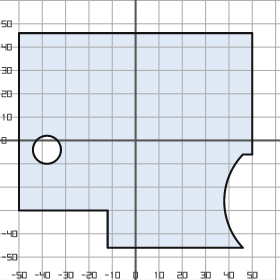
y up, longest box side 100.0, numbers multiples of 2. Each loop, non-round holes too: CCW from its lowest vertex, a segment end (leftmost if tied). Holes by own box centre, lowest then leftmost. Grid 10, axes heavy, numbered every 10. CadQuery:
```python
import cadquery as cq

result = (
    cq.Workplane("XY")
    .moveTo(-12.0, -46.0)
    .lineTo(46.0, -46.0)
    .threePointArc((38.0, -26.0), (46.0, -6.0))
    .lineTo(50.0, -6.0)
    .lineTo(50.0, 46.0)
    .lineTo(-50.0, 46.0)
    .lineTo(-50.0, -30.0)
    .lineTo(-12.0, -30.0)
    .close()
    .moveTo(-38.0, -4.0)
    .circle(6.0)
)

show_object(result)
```